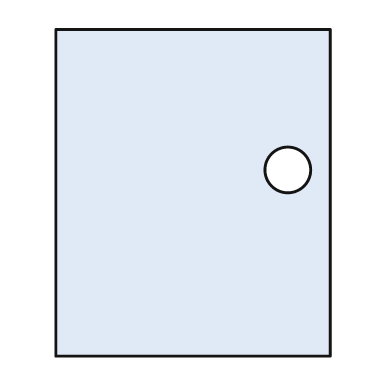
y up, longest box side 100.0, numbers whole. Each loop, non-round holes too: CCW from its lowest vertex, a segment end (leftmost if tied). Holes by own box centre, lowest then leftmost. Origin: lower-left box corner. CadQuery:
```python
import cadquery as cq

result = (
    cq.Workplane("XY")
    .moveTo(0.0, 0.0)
    .lineTo(84.0, 0.0)
    .lineTo(84.0, 100.0)
    .lineTo(0.0, 100.0)
    .close()
    .moveTo(71.0, 57.0)
    .circle(7.0)
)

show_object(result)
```